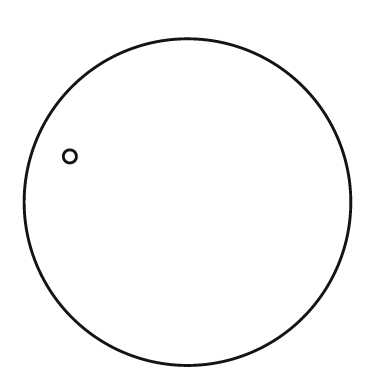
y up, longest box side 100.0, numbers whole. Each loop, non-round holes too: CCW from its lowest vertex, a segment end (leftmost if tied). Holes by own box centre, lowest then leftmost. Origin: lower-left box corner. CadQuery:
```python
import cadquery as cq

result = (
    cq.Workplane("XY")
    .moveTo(50.0, 50.0)
    .circle(50.0)
    .moveTo(14.0, 64.0)
    .circle(2.0)
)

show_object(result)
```